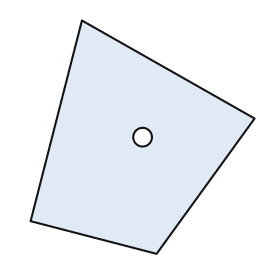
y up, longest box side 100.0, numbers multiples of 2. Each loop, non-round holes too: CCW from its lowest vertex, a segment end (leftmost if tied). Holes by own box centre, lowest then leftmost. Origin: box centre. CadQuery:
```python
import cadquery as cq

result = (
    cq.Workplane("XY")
    .moveTo(6.0, -50.0)
    .lineTo(48.0, 8.0)
    .lineTo(-26.0, 50.0)
    .lineTo(-48.0, -36.0)
    .close()
    .moveTo(0.0, 0.0)
    .circle(4.0)
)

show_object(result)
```